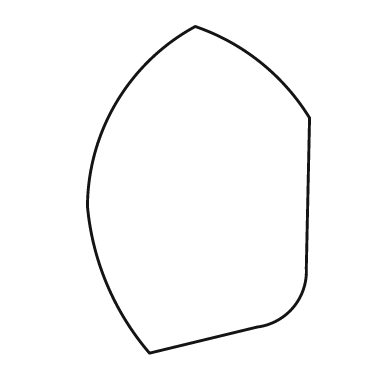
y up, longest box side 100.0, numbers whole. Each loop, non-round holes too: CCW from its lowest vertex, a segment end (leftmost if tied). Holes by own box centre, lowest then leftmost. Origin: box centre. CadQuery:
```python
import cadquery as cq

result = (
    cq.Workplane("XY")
    .moveTo(-15.0, -50.0)
    .lineTo(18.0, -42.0)
    .threePointArc((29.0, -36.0), (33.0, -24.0))
    .lineTo(34.0, 22.0)
    .threePointArc((19.0, 39.0), (-1.0, 50.0))
    .threePointArc((-25.0, 27.0), (-34.0, -5.0))
    .threePointArc((-28.0, -29.0), (-15.0, -50.0))
    .close()
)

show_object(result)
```